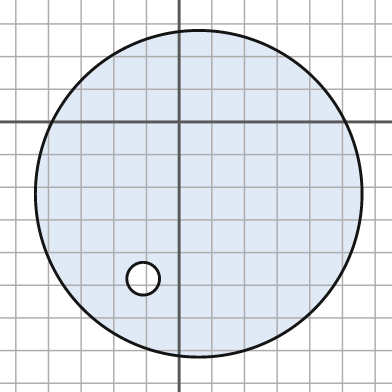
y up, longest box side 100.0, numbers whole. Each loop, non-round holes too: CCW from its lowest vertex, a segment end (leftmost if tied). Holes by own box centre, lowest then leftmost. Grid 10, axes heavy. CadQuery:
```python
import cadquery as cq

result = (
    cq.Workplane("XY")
    .moveTo(6.0, -22.0)
    .circle(50.0)
    .moveTo(-11.0, -48.0)
    .circle(5.0)
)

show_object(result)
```